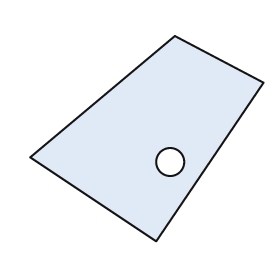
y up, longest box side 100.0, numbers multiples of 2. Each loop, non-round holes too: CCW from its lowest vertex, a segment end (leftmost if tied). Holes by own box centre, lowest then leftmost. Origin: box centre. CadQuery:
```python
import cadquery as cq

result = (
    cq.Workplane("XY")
    .moveTo(4.0, -44.0)
    .lineTo(50.0, 24.0)
    .lineTo(12.0, 44.0)
    .lineTo(-50.0, -8.0)
    .close()
    .moveTo(10.0, -10.0)
    .circle(6.0)
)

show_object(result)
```